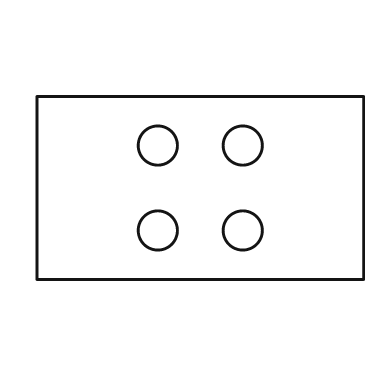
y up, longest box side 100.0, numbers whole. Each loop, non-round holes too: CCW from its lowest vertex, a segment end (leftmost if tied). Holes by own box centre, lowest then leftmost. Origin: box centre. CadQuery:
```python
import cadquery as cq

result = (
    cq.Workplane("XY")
    .moveTo(-50.0, -28.0)
    .lineTo(50.0, -28.0)
    .lineTo(50.0, 28.0)
    .lineTo(-50.0, 28.0)
    .close()
    .moveTo(-13.0, -13.0)
    .circle(6.0)
    .moveTo(13.0, -13.0)
    .circle(6.0)
    .moveTo(-13.0, 13.0)
    .circle(6.0)
    .moveTo(13.0, 13.0)
    .circle(6.0)
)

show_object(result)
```